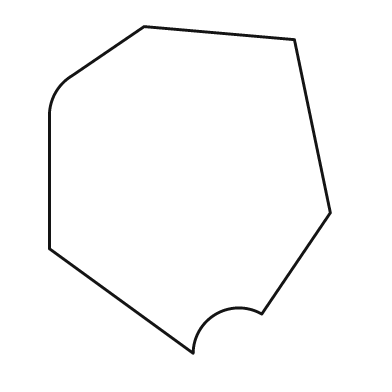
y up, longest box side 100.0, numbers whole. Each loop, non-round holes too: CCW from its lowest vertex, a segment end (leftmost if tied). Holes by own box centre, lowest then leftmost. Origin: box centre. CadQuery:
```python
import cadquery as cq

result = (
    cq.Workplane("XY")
    .moveTo(1.0, -50.0)
    .threePointArc((8.0, -38.0), (22.0, -38.0))
    .lineTo(43.0, -7.0)
    .lineTo(32.0, 46.0)
    .lineTo(-14.0, 50.0)
    .lineTo(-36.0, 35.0)
    .threePointArc((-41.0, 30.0), (-43.0, 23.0))
    .lineTo(-43.0, -18.0)
    .close()
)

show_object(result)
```